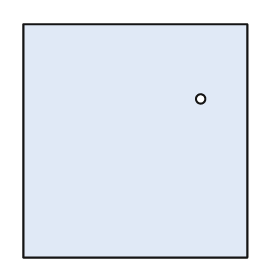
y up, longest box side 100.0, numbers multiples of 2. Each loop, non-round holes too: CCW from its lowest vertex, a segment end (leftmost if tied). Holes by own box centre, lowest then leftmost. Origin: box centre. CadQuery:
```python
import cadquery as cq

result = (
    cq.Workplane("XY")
    .moveTo(-48.0, -50.0)
    .lineTo(48.0, -50.0)
    .lineTo(48.0, 50.0)
    .lineTo(-48.0, 50.0)
    .close()
    .moveTo(28.0, 18.0)
    .circle(2.0)
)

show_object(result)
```